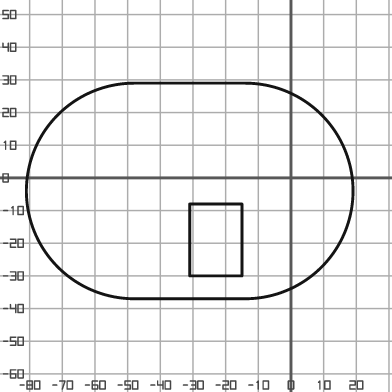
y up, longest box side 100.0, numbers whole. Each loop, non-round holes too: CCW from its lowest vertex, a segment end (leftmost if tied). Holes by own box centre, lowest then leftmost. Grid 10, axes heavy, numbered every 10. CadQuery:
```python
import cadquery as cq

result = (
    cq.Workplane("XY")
    .moveTo(-48.0, -37.0)
    .lineTo(-14.0, -37.0)
    .threePointArc((19.0, -4.0), (-14.0, 29.0))
    .lineTo(-48.0, 29.0)
    .threePointArc((-81.0, -4.0), (-48.0, -37.0))
    .close()
    .moveTo(-31.0, -30.0)
    .lineTo(-15.0, -30.0)
    .lineTo(-15.0, -8.0)
    .lineTo(-31.0, -8.0)
    .close()
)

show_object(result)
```